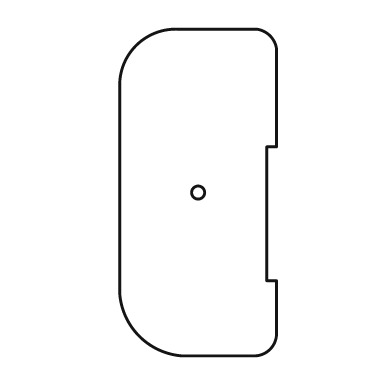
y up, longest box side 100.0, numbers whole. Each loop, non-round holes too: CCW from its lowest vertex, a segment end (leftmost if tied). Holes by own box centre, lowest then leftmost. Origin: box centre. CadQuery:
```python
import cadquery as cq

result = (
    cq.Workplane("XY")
    .moveTo(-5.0, -50.0)
    .lineTo(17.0, -50.0)
    .threePointArc((22.0, -48.0), (24.0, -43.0))
    .lineTo(24.0, -27.0)
    .lineTo(21.0, -27.0)
    .lineTo(21.0, 14.0)
    .lineTo(24.0, 14.0)
    .lineTo(24.0, 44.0)
    .threePointArc((22.0, 48.0), (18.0, 50.0))
    .lineTo(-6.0, 50.0)
    .threePointArc((-19.0, 45.0), (-24.0, 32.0))
    .lineTo(-24.0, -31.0)
    .threePointArc((-18.0, -44.0), (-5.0, -50.0))
    .close()
    .moveTo(0.0, 0.0)
    .circle(2.0)
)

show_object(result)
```